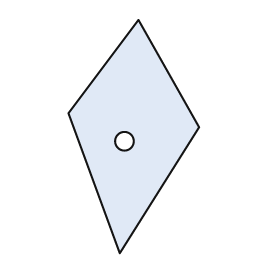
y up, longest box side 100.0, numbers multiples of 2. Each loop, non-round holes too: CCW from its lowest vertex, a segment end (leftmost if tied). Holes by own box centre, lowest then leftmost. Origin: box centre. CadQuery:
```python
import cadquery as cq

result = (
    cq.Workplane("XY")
    .moveTo(-6.0, -50.0)
    .lineTo(28.0, 4.0)
    .lineTo(2.0, 50.0)
    .lineTo(-28.0, 10.0)
    .close()
    .moveTo(-4.0, -2.0)
    .circle(4.0)
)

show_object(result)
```